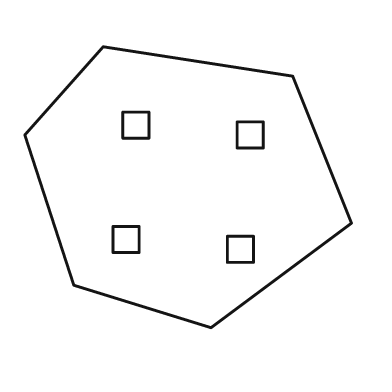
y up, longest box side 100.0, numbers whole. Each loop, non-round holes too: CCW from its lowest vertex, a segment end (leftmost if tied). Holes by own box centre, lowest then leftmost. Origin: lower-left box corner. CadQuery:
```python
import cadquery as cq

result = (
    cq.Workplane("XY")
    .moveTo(57.0, 0.0)
    .lineTo(100.0, 32.0)
    .lineTo(82.0, 77.0)
    .lineTo(24.0, 86.0)
    .lineTo(0.0, 59.0)
    .lineTo(15.0, 13.0)
    .close()
    .moveTo(62.0, 20.0)
    .lineTo(70.0, 20.0)
    .lineTo(70.0, 28.0)
    .lineTo(62.0, 28.0)
    .close()
    .moveTo(27.0, 23.0)
    .lineTo(35.0, 23.0)
    .lineTo(35.0, 31.0)
    .lineTo(27.0, 31.0)
    .close()
    .moveTo(65.0, 55.0)
    .lineTo(73.0, 55.0)
    .lineTo(73.0, 63.0)
    .lineTo(65.0, 63.0)
    .close()
    .moveTo(30.0, 58.0)
    .lineTo(38.0, 58.0)
    .lineTo(38.0, 66.0)
    .lineTo(30.0, 66.0)
    .close()
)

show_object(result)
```